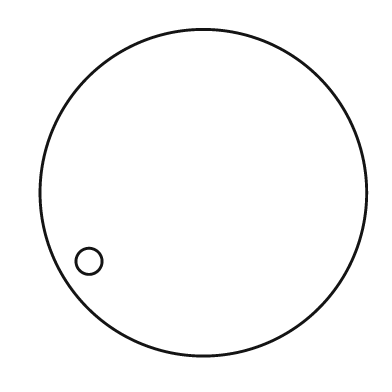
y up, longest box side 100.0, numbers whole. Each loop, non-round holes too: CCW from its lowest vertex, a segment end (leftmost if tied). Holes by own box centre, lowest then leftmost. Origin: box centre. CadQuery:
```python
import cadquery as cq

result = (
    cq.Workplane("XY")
    .moveTo(0.0, 0.0)
    .circle(50.0)
    .moveTo(-35.0, -21.0)
    .circle(4.0)
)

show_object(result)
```